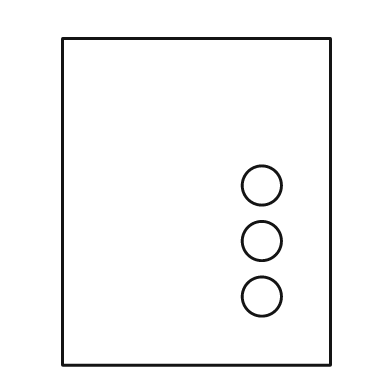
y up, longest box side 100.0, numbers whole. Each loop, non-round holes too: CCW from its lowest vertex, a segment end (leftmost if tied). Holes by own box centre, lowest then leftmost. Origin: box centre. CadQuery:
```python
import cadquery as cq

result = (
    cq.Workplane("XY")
    .moveTo(-41.0, -50.0)
    .lineTo(41.0, -50.0)
    .lineTo(41.0, 50.0)
    .lineTo(-41.0, 50.0)
    .close()
    .moveTo(20.0, -29.0)
    .circle(6.0)
    .moveTo(20.0, -12.0)
    .circle(6.0)
    .moveTo(20.0, 5.0)
    .circle(6.0)
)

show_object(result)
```